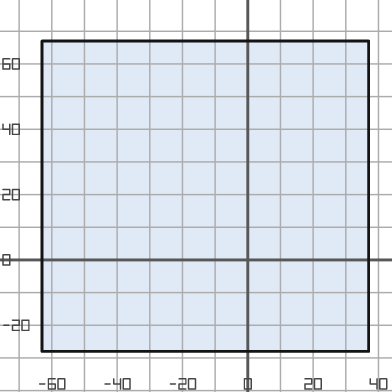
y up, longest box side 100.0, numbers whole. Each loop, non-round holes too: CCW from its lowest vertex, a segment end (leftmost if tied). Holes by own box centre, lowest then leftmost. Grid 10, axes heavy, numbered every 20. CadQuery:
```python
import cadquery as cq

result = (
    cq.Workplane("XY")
    .moveTo(-63.0, -28.0)
    .lineTo(37.0, -28.0)
    .lineTo(37.0, 67.0)
    .lineTo(-63.0, 67.0)
    .close()
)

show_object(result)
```